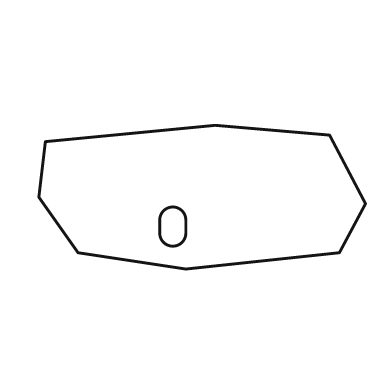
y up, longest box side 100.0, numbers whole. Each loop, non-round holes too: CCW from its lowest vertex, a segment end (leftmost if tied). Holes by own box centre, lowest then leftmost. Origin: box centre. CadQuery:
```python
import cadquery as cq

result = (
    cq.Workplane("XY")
    .moveTo(-5.0, -22.0)
    .lineTo(42.0, -17.0)
    .lineTo(50.0, -2.0)
    .lineTo(39.0, 19.0)
    .lineTo(4.0, 22.0)
    .lineTo(-48.0, 17.0)
    .lineTo(-50.0, 0.0)
    .lineTo(-38.0, -17.0)
    .close()
    .moveTo(-13.0, -11.0)
    .threePointArc((-9.0, -15.0), (-5.0, -11.0))
    .lineTo(-5.0, -7.0)
    .threePointArc((-9.0, -3.0), (-13.0, -7.0))
    .close()
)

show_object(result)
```